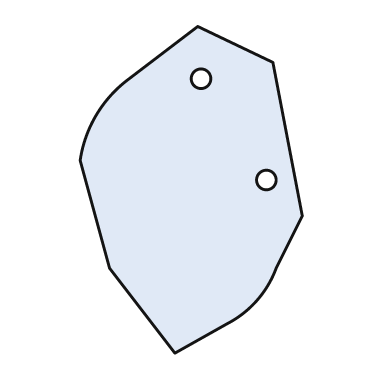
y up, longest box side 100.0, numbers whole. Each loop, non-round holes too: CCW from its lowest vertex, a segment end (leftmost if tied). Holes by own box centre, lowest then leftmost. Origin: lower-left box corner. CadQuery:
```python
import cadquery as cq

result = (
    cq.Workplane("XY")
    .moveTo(29.0, 0.0)
    .lineTo(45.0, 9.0)
    .threePointArc((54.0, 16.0), (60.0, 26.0))
    .lineTo(68.0, 42.0)
    .lineTo(59.0, 89.0)
    .lineTo(36.0, 100.0)
    .lineTo(15.0, 84.0)
    .threePointArc((5.0, 73.0), (0.0, 59.0))
    .lineTo(9.0, 26.0)
    .close()
    .moveTo(57.0, 53.0)
    .circle(3.0)
    .moveTo(37.0, 84.0)
    .circle(3.0)
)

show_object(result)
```